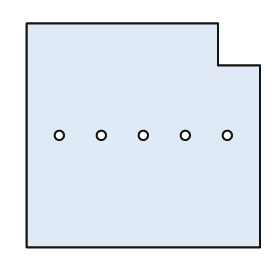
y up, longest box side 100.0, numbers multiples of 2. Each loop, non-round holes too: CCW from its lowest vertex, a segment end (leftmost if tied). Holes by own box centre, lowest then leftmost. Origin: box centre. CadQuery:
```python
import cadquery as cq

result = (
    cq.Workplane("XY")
    .moveTo(-50.0, -48.0)
    .lineTo(50.0, -48.0)
    .lineTo(50.0, 30.0)
    .lineTo(32.0, 30.0)
    .lineTo(32.0, 48.0)
    .lineTo(-50.0, 48.0)
    .close()
    .moveTo(-36.0, 0.0)
    .circle(2.0)
    .moveTo(-18.0, 0.0)
    .circle(2.0)
    .moveTo(0.0, 0.0)
    .circle(2.0)
    .moveTo(18.0, 0.0)
    .circle(2.0)
    .moveTo(36.0, 0.0)
    .circle(2.0)
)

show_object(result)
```